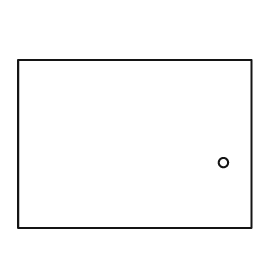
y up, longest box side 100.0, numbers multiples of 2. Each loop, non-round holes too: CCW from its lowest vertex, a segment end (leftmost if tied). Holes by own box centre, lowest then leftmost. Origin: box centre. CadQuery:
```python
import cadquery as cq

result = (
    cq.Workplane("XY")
    .moveTo(-50.0, -36.0)
    .lineTo(50.0, -36.0)
    .lineTo(50.0, 36.0)
    .lineTo(-50.0, 36.0)
    .close()
    .moveTo(38.0, -8.0)
    .circle(2.0)
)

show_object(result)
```